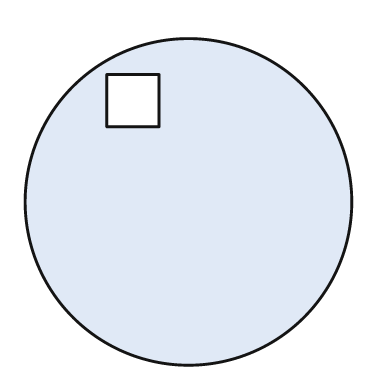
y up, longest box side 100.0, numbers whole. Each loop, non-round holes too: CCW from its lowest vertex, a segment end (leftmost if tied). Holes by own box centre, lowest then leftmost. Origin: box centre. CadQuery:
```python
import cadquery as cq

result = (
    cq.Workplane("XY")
    .moveTo(0.0, 0.0)
    .circle(50.0)
    .moveTo(-25.0, 23.0)
    .lineTo(-9.0, 23.0)
    .lineTo(-9.0, 39.0)
    .lineTo(-25.0, 39.0)
    .close()
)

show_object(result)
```